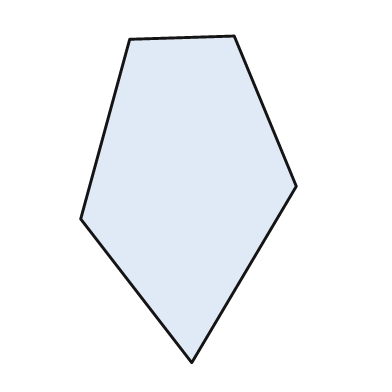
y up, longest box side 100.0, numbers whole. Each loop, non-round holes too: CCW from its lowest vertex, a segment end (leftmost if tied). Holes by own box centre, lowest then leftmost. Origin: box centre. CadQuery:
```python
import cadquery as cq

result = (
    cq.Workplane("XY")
    .moveTo(1.0, -50.0)
    .lineTo(33.0, 4.0)
    .lineTo(14.0, 50.0)
    .lineTo(-18.0, 49.0)
    .lineTo(-33.0, -6.0)
    .close()
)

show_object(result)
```